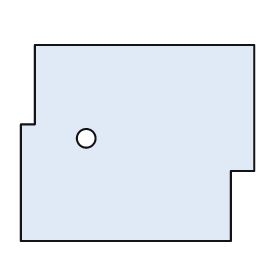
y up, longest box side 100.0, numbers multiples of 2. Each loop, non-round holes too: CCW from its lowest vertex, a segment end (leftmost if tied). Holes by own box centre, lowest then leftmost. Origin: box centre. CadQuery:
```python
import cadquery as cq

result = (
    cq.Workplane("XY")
    .moveTo(-50.0, -42.0)
    .lineTo(40.0, -42.0)
    .lineTo(40.0, -12.0)
    .lineTo(50.0, -12.0)
    .lineTo(50.0, 42.0)
    .lineTo(-44.0, 42.0)
    .lineTo(-44.0, 8.0)
    .lineTo(-50.0, 8.0)
    .close()
    .moveTo(-22.0, 2.0)
    .circle(4.0)
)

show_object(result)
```